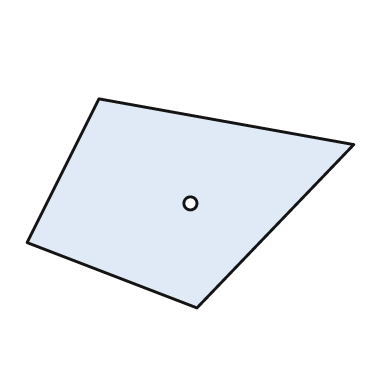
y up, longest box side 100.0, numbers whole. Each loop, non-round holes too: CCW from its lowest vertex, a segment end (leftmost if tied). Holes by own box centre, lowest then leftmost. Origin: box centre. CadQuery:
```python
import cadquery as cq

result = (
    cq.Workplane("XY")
    .moveTo(2.0, -32.0)
    .lineTo(50.0, 18.0)
    .lineTo(-28.0, 32.0)
    .lineTo(-50.0, -12.0)
    .close()
    .moveTo(0.0, 0.0)
    .circle(2.0)
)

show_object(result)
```